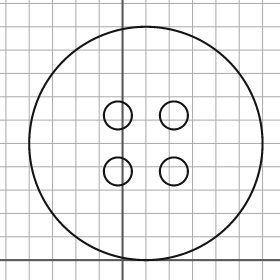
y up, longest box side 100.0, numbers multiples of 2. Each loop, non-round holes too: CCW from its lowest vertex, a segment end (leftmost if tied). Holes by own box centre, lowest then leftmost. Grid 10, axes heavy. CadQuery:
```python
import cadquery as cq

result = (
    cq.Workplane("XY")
    .moveTo(10.0, 50.0)
    .circle(50.0)
    .moveTo(-2.0, 38.0)
    .circle(6.0)
    .moveTo(22.0, 38.0)
    .circle(6.0)
    .moveTo(-2.0, 62.0)
    .circle(6.0)
    .moveTo(22.0, 62.0)
    .circle(6.0)
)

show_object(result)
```